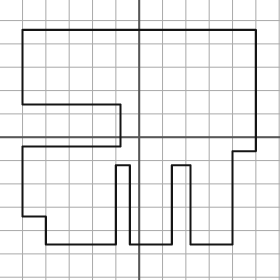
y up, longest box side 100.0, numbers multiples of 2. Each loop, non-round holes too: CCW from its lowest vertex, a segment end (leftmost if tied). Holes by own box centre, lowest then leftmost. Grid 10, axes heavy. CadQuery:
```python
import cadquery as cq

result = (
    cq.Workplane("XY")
    .moveTo(-40.0, -46.0)
    .lineTo(-10.0, -46.0)
    .lineTo(-10.0, -12.0)
    .lineTo(-4.0, -12.0)
    .lineTo(-4.0, -46.0)
    .lineTo(14.0, -46.0)
    .lineTo(14.0, -12.0)
    .lineTo(22.0, -12.0)
    .lineTo(22.0, -46.0)
    .lineTo(40.0, -46.0)
    .lineTo(40.0, -6.0)
    .lineTo(50.0, -6.0)
    .lineTo(50.0, 46.0)
    .lineTo(-50.0, 46.0)
    .lineTo(-50.0, 14.0)
    .lineTo(-8.0, 14.0)
    .lineTo(-8.0, -4.0)
    .lineTo(-50.0, -4.0)
    .lineTo(-50.0, -34.0)
    .lineTo(-40.0, -34.0)
    .close()
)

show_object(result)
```